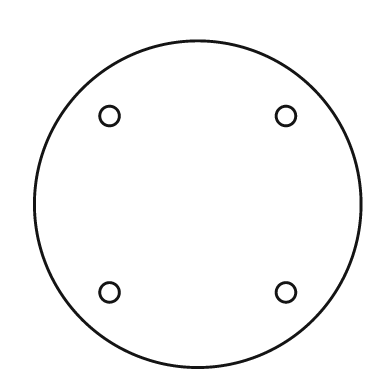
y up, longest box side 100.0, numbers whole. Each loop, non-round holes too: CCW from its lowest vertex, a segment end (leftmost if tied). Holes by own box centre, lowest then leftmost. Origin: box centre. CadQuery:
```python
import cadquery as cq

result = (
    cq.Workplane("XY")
    .moveTo(0.0, 0.0)
    .circle(50.0)
    .moveTo(-27.0, -27.0)
    .circle(3.0)
    .moveTo(27.0, -27.0)
    .circle(3.0)
    .moveTo(-27.0, 27.0)
    .circle(3.0)
    .moveTo(27.0, 27.0)
    .circle(3.0)
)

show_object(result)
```